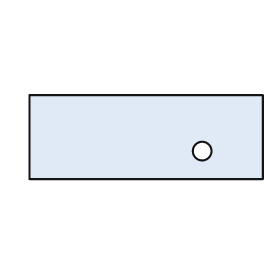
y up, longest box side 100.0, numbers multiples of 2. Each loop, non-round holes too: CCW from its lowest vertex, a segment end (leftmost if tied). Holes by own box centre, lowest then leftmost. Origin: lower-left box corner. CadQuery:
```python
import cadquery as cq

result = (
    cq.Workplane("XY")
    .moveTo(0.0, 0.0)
    .lineTo(100.0, 0.0)
    .lineTo(100.0, 36.0)
    .lineTo(0.0, 36.0)
    .close()
    .moveTo(74.0, 12.0)
    .circle(4.0)
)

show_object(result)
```